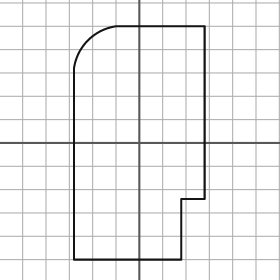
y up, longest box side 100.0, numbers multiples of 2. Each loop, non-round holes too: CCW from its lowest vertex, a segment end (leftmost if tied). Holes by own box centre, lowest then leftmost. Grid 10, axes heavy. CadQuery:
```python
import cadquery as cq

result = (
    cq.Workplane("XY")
    .moveTo(-28.0, -50.0)
    .lineTo(18.0, -50.0)
    .lineTo(18.0, -24.0)
    .lineTo(28.0, -24.0)
    .lineTo(28.0, 50.0)
    .lineTo(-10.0, 50.0)
    .threePointArc((-22.0, 44.0), (-28.0, 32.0))
    .close()
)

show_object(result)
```